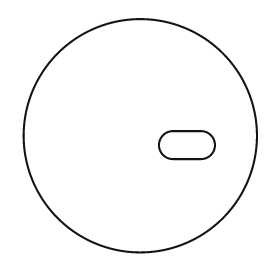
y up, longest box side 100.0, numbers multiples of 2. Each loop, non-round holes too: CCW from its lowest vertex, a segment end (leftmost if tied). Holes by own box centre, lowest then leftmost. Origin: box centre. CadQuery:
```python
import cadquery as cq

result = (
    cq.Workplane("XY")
    .moveTo(0.0, 0.0)
    .circle(50.0)
    .moveTo(14.0, -10.0)
    .lineTo(26.0, -10.0)
    .threePointArc((32.0, -4.0), (26.0, 2.0))
    .lineTo(14.0, 2.0)
    .threePointArc((8.0, -4.0), (14.0, -10.0))
    .close()
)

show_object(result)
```